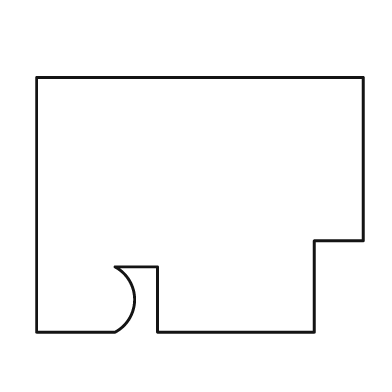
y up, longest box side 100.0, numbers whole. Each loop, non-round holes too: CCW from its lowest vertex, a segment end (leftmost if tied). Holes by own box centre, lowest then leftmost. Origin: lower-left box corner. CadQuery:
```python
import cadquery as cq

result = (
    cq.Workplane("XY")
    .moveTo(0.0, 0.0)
    .lineTo(24.0, 0.0)
    .threePointArc((30.0, 10.0), (24.0, 20.0))
    .lineTo(37.0, 20.0)
    .lineTo(37.0, 0.0)
    .lineTo(85.0, 0.0)
    .lineTo(85.0, 28.0)
    .lineTo(100.0, 28.0)
    .lineTo(100.0, 78.0)
    .lineTo(0.0, 78.0)
    .close()
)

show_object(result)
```